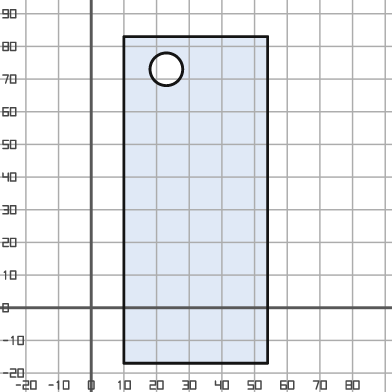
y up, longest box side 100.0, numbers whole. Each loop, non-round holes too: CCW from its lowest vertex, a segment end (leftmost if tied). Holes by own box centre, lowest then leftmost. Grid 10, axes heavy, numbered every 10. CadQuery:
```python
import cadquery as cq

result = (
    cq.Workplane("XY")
    .moveTo(10.0, -17.0)
    .lineTo(54.0, -17.0)
    .lineTo(54.0, 83.0)
    .lineTo(10.0, 83.0)
    .close()
    .moveTo(23.0, 73.0)
    .circle(5.0)
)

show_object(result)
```